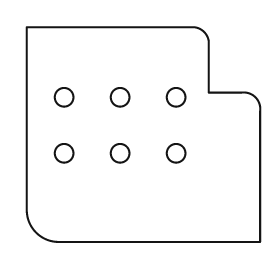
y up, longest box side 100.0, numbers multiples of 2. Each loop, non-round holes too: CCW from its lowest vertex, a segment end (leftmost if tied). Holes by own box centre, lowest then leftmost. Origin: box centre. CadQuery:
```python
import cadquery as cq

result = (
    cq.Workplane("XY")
    .moveTo(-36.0, -46.0)
    .lineTo(50.0, -46.0)
    .lineTo(50.0, 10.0)
    .threePointArc((48.0, 16.0), (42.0, 18.0))
    .lineTo(28.0, 18.0)
    .lineTo(28.0, 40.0)
    .threePointArc((26.0, 44.0), (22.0, 46.0))
    .lineTo(-50.0, 46.0)
    .lineTo(-50.0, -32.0)
    .threePointArc((-46.0, -42.0), (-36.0, -46.0))
    .close()
    .moveTo(-34.0, -8.0)
    .circle(4.0)
    .moveTo(-10.0, -8.0)
    .circle(4.0)
    .moveTo(14.0, -8.0)
    .circle(4.0)
    .moveTo(-34.0, 16.0)
    .circle(4.0)
    .moveTo(-10.0, 16.0)
    .circle(4.0)
    .moveTo(14.0, 16.0)
    .circle(4.0)
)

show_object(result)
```